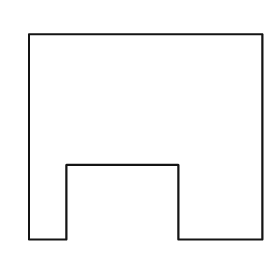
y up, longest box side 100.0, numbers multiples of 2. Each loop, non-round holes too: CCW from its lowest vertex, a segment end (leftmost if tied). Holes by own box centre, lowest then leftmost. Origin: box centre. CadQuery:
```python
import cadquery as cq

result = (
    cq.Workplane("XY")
    .moveTo(-50.0, -44.0)
    .lineTo(-34.0, -44.0)
    .lineTo(-34.0, -12.0)
    .lineTo(14.0, -12.0)
    .lineTo(14.0, -44.0)
    .lineTo(50.0, -44.0)
    .lineTo(50.0, 44.0)
    .lineTo(-50.0, 44.0)
    .close()
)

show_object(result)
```